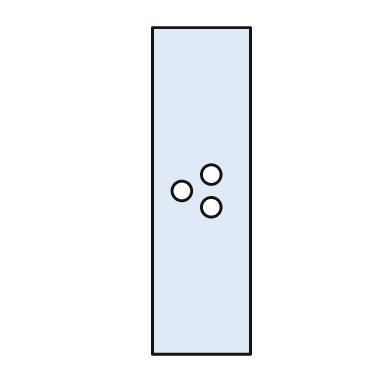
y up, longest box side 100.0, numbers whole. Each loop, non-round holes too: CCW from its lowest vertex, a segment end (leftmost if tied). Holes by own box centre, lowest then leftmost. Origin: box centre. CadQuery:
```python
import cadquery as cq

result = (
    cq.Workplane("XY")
    .moveTo(-15.0, -50.0)
    .lineTo(15.0, -50.0)
    .lineTo(15.0, 50.0)
    .lineTo(-15.0, 50.0)
    .close()
    .moveTo(3.0, -5.0)
    .circle(3.0)
    .moveTo(-6.0, 0.0)
    .circle(3.0)
    .moveTo(3.0, 5.0)
    .circle(3.0)
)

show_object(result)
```